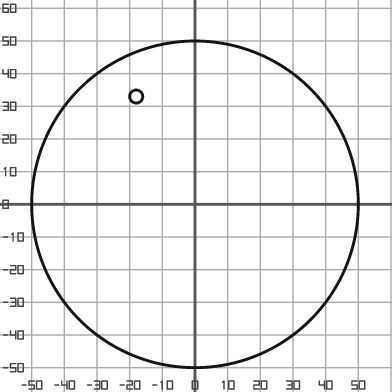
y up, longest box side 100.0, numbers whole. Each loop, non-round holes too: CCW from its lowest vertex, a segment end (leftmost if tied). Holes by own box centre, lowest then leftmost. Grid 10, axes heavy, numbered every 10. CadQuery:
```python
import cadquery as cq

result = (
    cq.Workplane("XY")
    .moveTo(0.0, 0.0)
    .circle(50.0)
    .moveTo(-18.0, 33.0)
    .circle(2.0)
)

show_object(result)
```